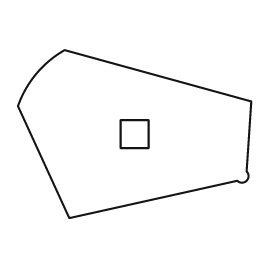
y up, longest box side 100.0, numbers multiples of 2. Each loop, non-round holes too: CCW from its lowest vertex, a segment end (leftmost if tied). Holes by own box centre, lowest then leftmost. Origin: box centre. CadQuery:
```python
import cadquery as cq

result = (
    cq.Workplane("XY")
    .moveTo(-28.0, -36.0)
    .lineTo(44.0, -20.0)
    .threePointArc((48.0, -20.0), (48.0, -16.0))
    .lineTo(50.0, 14.0)
    .lineTo(-30.0, 36.0)
    .threePointArc((-42.0, 26.0), (-50.0, 12.0))
    .close()
    .moveTo(-6.0, -6.0)
    .lineTo(6.0, -6.0)
    .lineTo(6.0, 6.0)
    .lineTo(-6.0, 6.0)
    .close()
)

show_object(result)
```